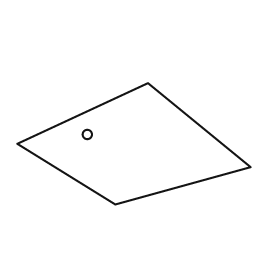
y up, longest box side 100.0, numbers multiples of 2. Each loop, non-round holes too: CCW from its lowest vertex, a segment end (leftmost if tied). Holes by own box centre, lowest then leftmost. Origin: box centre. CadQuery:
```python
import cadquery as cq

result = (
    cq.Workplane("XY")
    .moveTo(-8.0, -26.0)
    .lineTo(50.0, -10.0)
    .lineTo(6.0, 26.0)
    .lineTo(-50.0, 0.0)
    .close()
    .moveTo(-20.0, 4.0)
    .circle(2.0)
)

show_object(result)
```